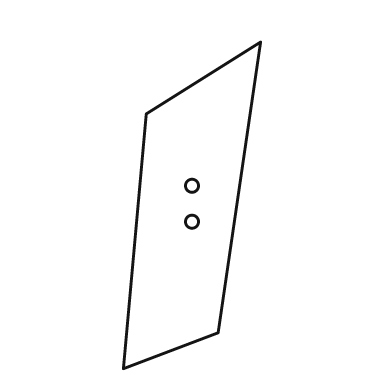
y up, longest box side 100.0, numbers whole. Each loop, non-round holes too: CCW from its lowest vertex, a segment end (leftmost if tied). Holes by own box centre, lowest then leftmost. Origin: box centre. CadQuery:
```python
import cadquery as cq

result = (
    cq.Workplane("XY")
    .moveTo(-21.0, -50.0)
    .lineTo(8.0, -39.0)
    .lineTo(21.0, 50.0)
    .lineTo(-14.0, 28.0)
    .close()
    .moveTo(0.0, -5.0)
    .circle(2.0)
    .moveTo(0.0, 6.0)
    .circle(2.0)
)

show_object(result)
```